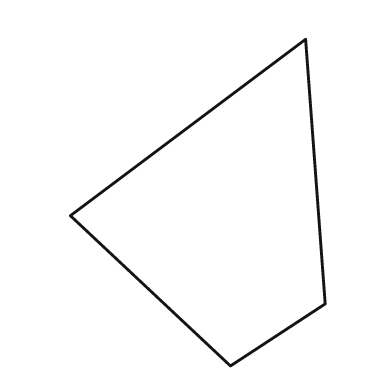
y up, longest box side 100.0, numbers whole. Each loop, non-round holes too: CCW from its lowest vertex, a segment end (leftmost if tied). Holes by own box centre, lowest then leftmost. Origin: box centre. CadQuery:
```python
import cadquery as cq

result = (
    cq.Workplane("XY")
    .moveTo(10.0, -50.0)
    .lineTo(39.0, -31.0)
    .lineTo(33.0, 50.0)
    .lineTo(-39.0, -4.0)
    .close()
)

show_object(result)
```